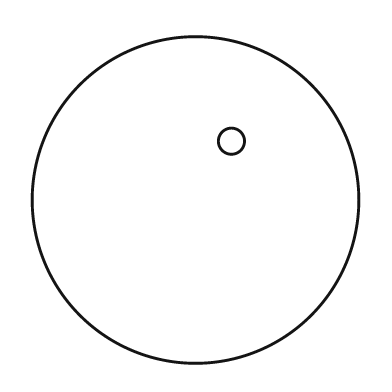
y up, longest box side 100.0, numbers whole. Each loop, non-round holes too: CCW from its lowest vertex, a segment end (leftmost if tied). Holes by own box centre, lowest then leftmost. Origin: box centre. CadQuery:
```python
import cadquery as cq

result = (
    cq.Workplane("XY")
    .moveTo(0.0, 0.0)
    .circle(50.0)
    .moveTo(11.0, 18.0)
    .circle(4.0)
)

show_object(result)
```